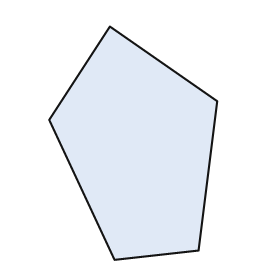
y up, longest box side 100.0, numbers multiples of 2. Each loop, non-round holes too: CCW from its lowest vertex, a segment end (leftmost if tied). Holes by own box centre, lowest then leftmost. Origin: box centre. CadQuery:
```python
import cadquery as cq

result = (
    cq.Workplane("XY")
    .moveTo(-8.0, -50.0)
    .lineTo(28.0, -46.0)
    .lineTo(36.0, 18.0)
    .lineTo(-10.0, 50.0)
    .lineTo(-36.0, 10.0)
    .close()
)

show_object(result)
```